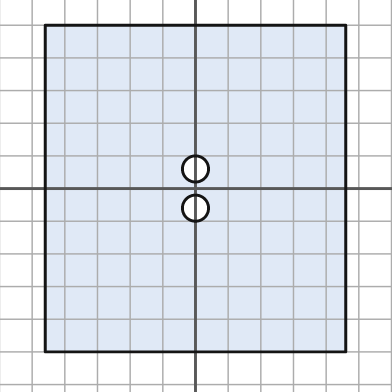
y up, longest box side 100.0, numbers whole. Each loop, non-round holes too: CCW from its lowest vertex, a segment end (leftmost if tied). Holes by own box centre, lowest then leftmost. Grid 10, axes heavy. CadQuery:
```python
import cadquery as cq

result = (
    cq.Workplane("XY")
    .moveTo(-46.0, -50.0)
    .lineTo(46.0, -50.0)
    .lineTo(46.0, 50.0)
    .lineTo(-46.0, 50.0)
    .close()
    .moveTo(0.0, -6.0)
    .circle(4.0)
    .moveTo(0.0, 6.0)
    .circle(4.0)
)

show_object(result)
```